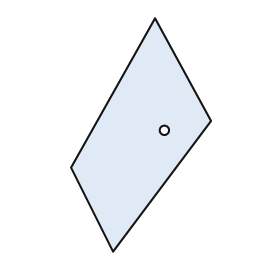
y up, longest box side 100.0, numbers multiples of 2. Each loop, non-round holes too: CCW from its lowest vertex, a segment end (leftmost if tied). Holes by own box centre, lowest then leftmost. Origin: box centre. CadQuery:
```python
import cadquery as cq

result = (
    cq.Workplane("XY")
    .moveTo(-12.0, -50.0)
    .lineTo(30.0, 6.0)
    .lineTo(6.0, 50.0)
    .lineTo(-30.0, -14.0)
    .close()
    .moveTo(10.0, 2.0)
    .circle(2.0)
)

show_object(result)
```